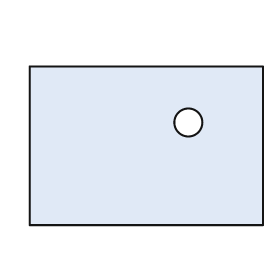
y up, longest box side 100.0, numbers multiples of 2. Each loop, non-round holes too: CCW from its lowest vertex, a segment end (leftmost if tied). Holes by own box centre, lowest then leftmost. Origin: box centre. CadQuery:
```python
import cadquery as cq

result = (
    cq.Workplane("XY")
    .moveTo(-50.0, -34.0)
    .lineTo(50.0, -34.0)
    .lineTo(50.0, 34.0)
    .lineTo(-50.0, 34.0)
    .close()
    .moveTo(18.0, 10.0)
    .circle(6.0)
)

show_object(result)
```